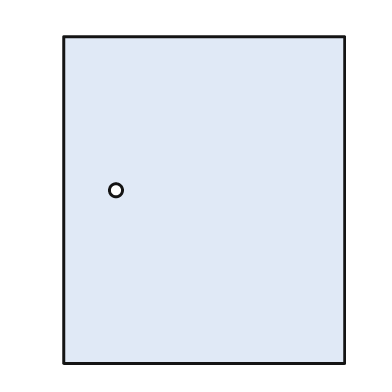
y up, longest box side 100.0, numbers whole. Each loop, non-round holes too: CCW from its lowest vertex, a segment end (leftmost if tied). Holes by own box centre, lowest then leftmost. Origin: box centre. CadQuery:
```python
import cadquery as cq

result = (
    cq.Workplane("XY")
    .moveTo(-43.0, -50.0)
    .lineTo(43.0, -50.0)
    .lineTo(43.0, 50.0)
    .lineTo(-43.0, 50.0)
    .close()
    .moveTo(-27.0, 3.0)
    .circle(2.0)
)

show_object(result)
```